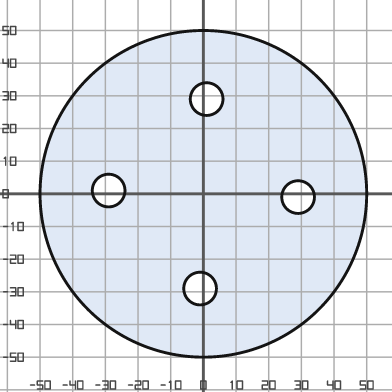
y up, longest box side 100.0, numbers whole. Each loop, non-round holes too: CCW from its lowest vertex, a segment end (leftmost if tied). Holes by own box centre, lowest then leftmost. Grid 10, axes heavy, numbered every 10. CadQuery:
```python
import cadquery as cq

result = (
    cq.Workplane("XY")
    .moveTo(0.0, 0.0)
    .circle(50.0)
    .moveTo(-1.0, -29.0)
    .circle(5.0)
    .moveTo(29.0, -1.0)
    .circle(5.0)
    .moveTo(-29.0, 1.0)
    .circle(5.0)
    .moveTo(1.0, 29.0)
    .circle(5.0)
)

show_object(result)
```